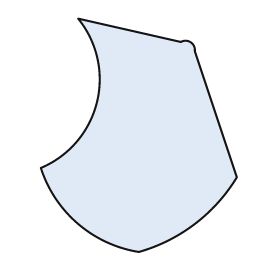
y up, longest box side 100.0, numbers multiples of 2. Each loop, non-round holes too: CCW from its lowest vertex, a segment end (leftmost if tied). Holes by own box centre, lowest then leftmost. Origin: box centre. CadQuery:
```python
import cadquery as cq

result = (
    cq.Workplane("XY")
    .moveTo(0.0, -50.0)
    .threePointArc((24.0, -38.0), (42.0, -18.0))
    .lineTo(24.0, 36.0)
    .threePointArc((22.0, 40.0), (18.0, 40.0))
    .lineTo(-26.0, 50.0)
    .threePointArc((-18.0, 14.0), (-42.0, -14.0))
    .threePointArc((-26.0, -38.0), (0.0, -50.0))
    .close()
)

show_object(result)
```